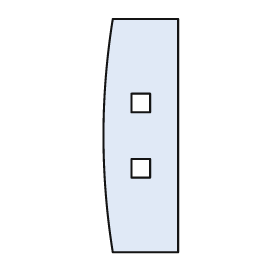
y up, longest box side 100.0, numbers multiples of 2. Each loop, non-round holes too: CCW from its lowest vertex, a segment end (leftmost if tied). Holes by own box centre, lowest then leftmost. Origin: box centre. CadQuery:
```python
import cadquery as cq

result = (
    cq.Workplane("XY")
    .moveTo(-12.0, -50.0)
    .lineTo(16.0, -50.0)
    .lineTo(16.0, 50.0)
    .lineTo(-12.0, 50.0)
    .threePointArc((-16.0, 0.0), (-12.0, -50.0))
    .close()
    .moveTo(-4.0, -18.0)
    .lineTo(4.0, -18.0)
    .lineTo(4.0, -10.0)
    .lineTo(-4.0, -10.0)
    .close()
    .moveTo(-4.0, 10.0)
    .lineTo(4.0, 10.0)
    .lineTo(4.0, 18.0)
    .lineTo(-4.0, 18.0)
    .close()
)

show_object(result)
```